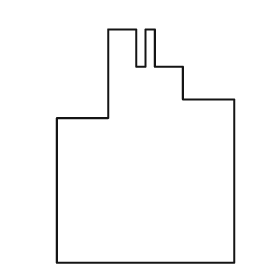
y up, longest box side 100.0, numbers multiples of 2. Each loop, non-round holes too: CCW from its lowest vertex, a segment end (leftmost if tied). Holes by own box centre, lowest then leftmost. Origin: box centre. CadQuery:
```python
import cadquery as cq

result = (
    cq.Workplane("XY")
    .moveTo(-38.0, -50.0)
    .lineTo(38.0, -50.0)
    .lineTo(38.0, 20.0)
    .lineTo(16.0, 20.0)
    .lineTo(16.0, 34.0)
    .lineTo(4.0, 34.0)
    .lineTo(4.0, 50.0)
    .lineTo(0.0, 50.0)
    .lineTo(0.0, 34.0)
    .lineTo(-4.0, 34.0)
    .lineTo(-4.0, 50.0)
    .lineTo(-16.0, 50.0)
    .lineTo(-16.0, 12.0)
    .lineTo(-38.0, 12.0)
    .close()
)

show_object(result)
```